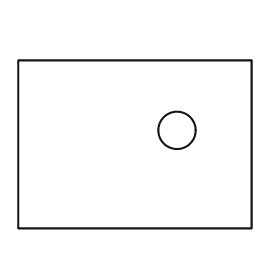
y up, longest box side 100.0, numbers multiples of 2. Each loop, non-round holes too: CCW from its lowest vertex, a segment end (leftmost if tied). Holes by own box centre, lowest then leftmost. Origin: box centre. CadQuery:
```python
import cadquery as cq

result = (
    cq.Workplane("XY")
    .moveTo(-50.0, -36.0)
    .lineTo(50.0, -36.0)
    .lineTo(50.0, 36.0)
    .lineTo(-50.0, 36.0)
    .close()
    .moveTo(18.0, 6.0)
    .circle(8.0)
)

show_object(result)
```